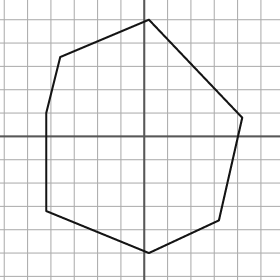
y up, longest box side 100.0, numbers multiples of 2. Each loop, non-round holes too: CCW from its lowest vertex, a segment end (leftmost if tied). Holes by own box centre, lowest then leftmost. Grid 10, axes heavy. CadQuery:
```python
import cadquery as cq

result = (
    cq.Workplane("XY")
    .moveTo(2.0, -50.0)
    .lineTo(32.0, -36.0)
    .lineTo(42.0, 8.0)
    .lineTo(2.0, 50.0)
    .lineTo(-36.0, 34.0)
    .lineTo(-42.0, 10.0)
    .lineTo(-42.0, -32.0)
    .close()
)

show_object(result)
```